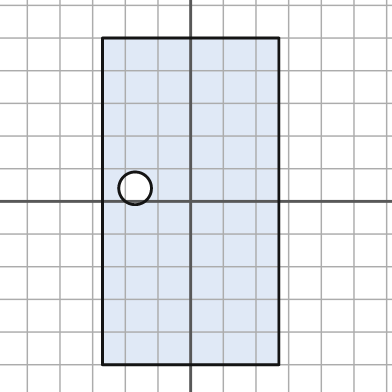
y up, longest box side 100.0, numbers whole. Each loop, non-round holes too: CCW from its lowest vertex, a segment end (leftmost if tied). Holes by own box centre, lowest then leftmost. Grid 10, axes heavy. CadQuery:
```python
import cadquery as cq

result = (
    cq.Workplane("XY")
    .moveTo(-27.0, -50.0)
    .lineTo(27.0, -50.0)
    .lineTo(27.0, 50.0)
    .lineTo(-27.0, 50.0)
    .close()
    .moveTo(-17.0, 4.0)
    .circle(5.0)
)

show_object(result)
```